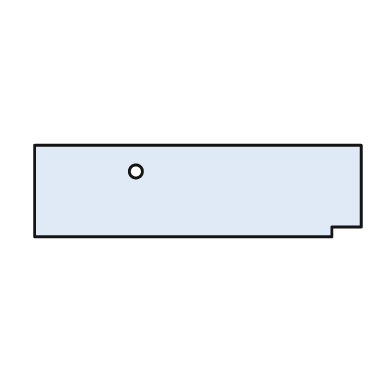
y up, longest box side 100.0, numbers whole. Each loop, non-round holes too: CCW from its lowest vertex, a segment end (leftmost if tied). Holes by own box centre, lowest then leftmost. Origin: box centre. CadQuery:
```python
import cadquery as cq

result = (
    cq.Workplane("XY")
    .moveTo(-50.0, -14.0)
    .lineTo(41.0, -14.0)
    .lineTo(41.0, -11.0)
    .lineTo(50.0, -11.0)
    .lineTo(50.0, 14.0)
    .lineTo(-50.0, 14.0)
    .close()
    .moveTo(-19.0, 6.0)
    .circle(2.0)
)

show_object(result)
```